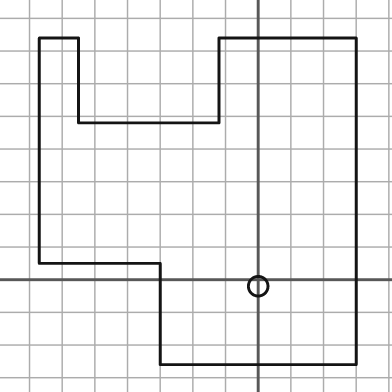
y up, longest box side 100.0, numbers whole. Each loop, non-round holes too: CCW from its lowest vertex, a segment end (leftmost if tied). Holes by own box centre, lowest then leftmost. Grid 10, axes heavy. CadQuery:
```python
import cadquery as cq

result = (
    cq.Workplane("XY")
    .moveTo(-30.0, -26.0)
    .lineTo(30.0, -26.0)
    .lineTo(30.0, 74.0)
    .lineTo(-12.0, 74.0)
    .lineTo(-12.0, 48.0)
    .lineTo(-55.0, 48.0)
    .lineTo(-55.0, 74.0)
    .lineTo(-67.0, 74.0)
    .lineTo(-67.0, 5.0)
    .lineTo(-30.0, 5.0)
    .close()
    .moveTo(0.0, -2.0)
    .circle(3.0)
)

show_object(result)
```